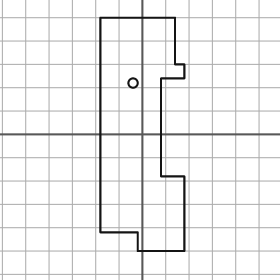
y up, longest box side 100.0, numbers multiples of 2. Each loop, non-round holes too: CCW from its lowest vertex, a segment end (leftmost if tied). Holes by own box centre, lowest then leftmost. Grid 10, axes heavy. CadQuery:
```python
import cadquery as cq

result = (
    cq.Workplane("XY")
    .moveTo(-2.0, -50.0)
    .lineTo(18.0, -50.0)
    .lineTo(18.0, -18.0)
    .lineTo(8.0, -18.0)
    .lineTo(8.0, 24.0)
    .lineTo(18.0, 24.0)
    .lineTo(18.0, 30.0)
    .lineTo(14.0, 30.0)
    .lineTo(14.0, 50.0)
    .lineTo(-18.0, 50.0)
    .lineTo(-18.0, -42.0)
    .lineTo(-2.0, -42.0)
    .close()
    .moveTo(-4.0, 22.0)
    .circle(2.0)
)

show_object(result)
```